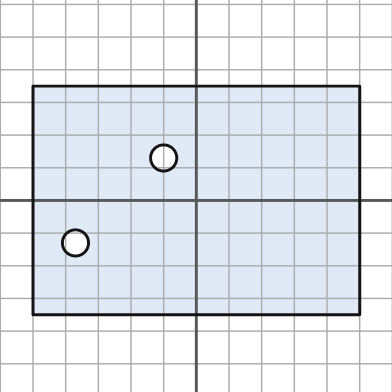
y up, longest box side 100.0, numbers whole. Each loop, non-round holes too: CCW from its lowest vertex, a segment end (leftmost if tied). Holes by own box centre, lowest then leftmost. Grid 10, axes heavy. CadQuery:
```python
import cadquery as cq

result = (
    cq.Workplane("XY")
    .moveTo(-50.0, -35.0)
    .lineTo(50.0, -35.0)
    .lineTo(50.0, 35.0)
    .lineTo(-50.0, 35.0)
    .close()
    .moveTo(-37.0, -13.0)
    .circle(4.0)
    .moveTo(-10.0, 13.0)
    .circle(4.0)
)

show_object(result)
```